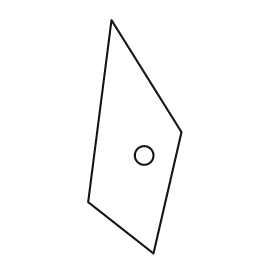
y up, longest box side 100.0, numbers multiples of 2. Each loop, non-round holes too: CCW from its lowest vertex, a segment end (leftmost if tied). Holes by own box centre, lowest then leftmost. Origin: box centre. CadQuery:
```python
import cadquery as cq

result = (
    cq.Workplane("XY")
    .moveTo(8.0, -50.0)
    .lineTo(20.0, 2.0)
    .lineTo(-10.0, 50.0)
    .lineTo(-20.0, -28.0)
    .close()
    .moveTo(4.0, -8.0)
    .circle(4.0)
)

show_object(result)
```